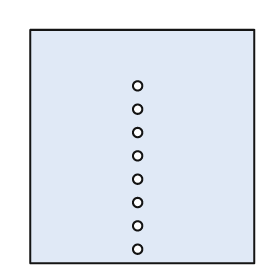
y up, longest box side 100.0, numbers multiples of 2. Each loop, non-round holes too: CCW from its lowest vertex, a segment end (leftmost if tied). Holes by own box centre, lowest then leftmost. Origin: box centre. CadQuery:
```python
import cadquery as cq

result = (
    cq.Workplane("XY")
    .moveTo(-48.0, -50.0)
    .lineTo(48.0, -50.0)
    .lineTo(48.0, 50.0)
    .lineTo(-48.0, 50.0)
    .close()
    .moveTo(-2.0, -44.0)
    .circle(2.0)
    .moveTo(-2.0, -34.0)
    .circle(2.0)
    .moveTo(-2.0, -24.0)
    .circle(2.0)
    .moveTo(-2.0, -14.0)
    .circle(2.0)
    .moveTo(-2.0, -4.0)
    .circle(2.0)
    .moveTo(-2.0, 6.0)
    .circle(2.0)
    .moveTo(-2.0, 16.0)
    .circle(2.0)
    .moveTo(-2.0, 26.0)
    .circle(2.0)
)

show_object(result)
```